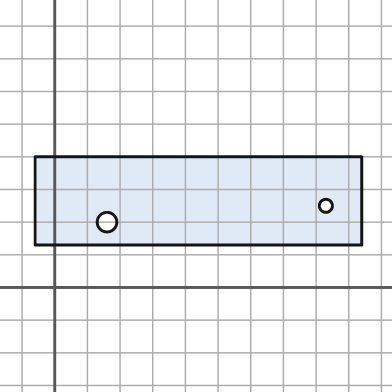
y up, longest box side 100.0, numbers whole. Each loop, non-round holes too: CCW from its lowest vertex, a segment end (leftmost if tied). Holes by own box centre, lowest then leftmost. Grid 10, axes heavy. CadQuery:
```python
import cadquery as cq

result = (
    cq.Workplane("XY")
    .moveTo(-6.0, 13.0)
    .lineTo(94.0, 13.0)
    .lineTo(94.0, 40.0)
    .lineTo(-6.0, 40.0)
    .close()
    .moveTo(16.0, 20.0)
    .circle(3.0)
    .moveTo(83.0, 25.0)
    .circle(2.0)
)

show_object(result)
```